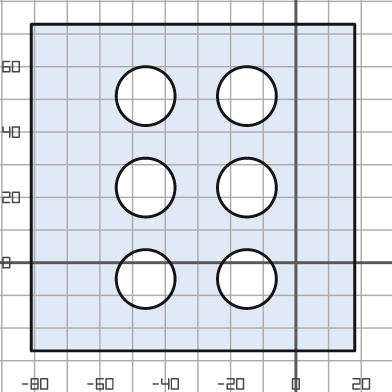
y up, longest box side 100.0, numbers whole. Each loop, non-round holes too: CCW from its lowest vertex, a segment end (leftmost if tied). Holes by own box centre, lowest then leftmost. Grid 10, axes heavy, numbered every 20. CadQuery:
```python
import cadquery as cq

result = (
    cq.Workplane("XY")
    .moveTo(-81.0, -27.0)
    .lineTo(18.0, -27.0)
    .lineTo(18.0, 73.0)
    .lineTo(-81.0, 73.0)
    .close()
    .moveTo(-46.0, -5.0)
    .circle(9.0)
    .moveTo(-15.0, -5.0)
    .circle(9.0)
    .moveTo(-46.0, 23.0)
    .circle(9.0)
    .moveTo(-15.0, 23.0)
    .circle(9.0)
    .moveTo(-46.0, 51.0)
    .circle(9.0)
    .moveTo(-15.0, 51.0)
    .circle(9.0)
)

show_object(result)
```